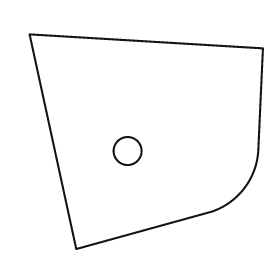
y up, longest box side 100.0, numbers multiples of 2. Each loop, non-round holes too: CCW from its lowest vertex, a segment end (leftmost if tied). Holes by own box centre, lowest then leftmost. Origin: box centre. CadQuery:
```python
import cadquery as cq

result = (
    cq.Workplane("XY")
    .moveTo(-30.0, -46.0)
    .lineTo(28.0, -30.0)
    .threePointArc((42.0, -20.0), (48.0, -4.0))
    .lineTo(50.0, 40.0)
    .lineTo(-50.0, 46.0)
    .close()
    .moveTo(-8.0, -4.0)
    .circle(6.0)
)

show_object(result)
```